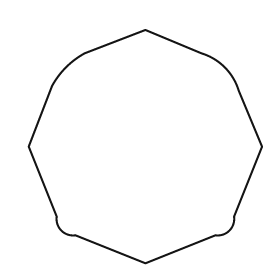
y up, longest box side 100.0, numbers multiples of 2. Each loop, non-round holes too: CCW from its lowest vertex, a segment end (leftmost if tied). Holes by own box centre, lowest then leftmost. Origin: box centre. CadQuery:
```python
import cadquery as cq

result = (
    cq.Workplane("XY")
    .moveTo(0.0, -50.0)
    .lineTo(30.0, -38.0)
    .threePointArc((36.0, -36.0), (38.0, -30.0))
    .lineTo(50.0, 0.0)
    .lineTo(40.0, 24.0)
    .threePointArc((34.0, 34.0), (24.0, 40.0))
    .lineTo(0.0, 50.0)
    .lineTo(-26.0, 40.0)
    .threePointArc((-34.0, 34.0), (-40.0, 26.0))
    .lineTo(-50.0, 0.0)
    .lineTo(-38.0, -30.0)
    .threePointArc((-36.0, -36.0), (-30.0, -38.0))
    .close()
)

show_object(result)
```